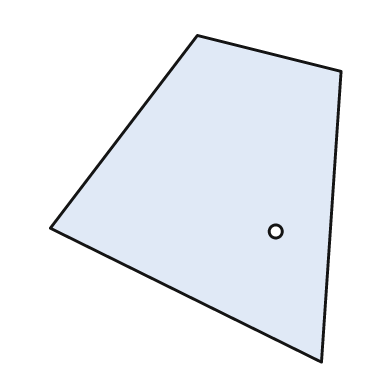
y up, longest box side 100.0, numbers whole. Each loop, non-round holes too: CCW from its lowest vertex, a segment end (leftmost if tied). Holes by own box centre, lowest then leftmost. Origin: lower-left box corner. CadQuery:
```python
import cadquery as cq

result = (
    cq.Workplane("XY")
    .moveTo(83.0, 0.0)
    .lineTo(89.0, 89.0)
    .lineTo(45.0, 100.0)
    .lineTo(0.0, 41.0)
    .close()
    .moveTo(69.0, 40.0)
    .circle(2.0)
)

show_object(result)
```